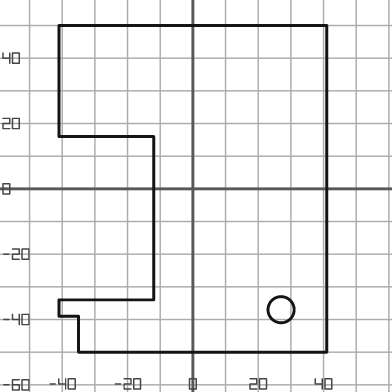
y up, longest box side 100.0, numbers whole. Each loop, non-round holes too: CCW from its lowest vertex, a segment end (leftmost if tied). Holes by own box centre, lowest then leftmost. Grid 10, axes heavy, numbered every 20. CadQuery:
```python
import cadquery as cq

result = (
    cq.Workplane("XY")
    .moveTo(-35.0, -50.0)
    .lineTo(41.0, -50.0)
    .lineTo(41.0, 50.0)
    .lineTo(-41.0, 50.0)
    .lineTo(-41.0, 16.0)
    .lineTo(-12.0, 16.0)
    .lineTo(-12.0, -34.0)
    .lineTo(-41.0, -34.0)
    .lineTo(-41.0, -39.0)
    .lineTo(-35.0, -39.0)
    .close()
    .moveTo(27.0, -37.0)
    .circle(4.0)
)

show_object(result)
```